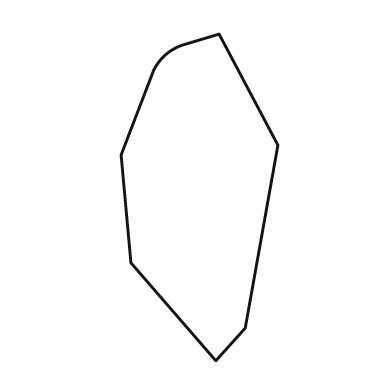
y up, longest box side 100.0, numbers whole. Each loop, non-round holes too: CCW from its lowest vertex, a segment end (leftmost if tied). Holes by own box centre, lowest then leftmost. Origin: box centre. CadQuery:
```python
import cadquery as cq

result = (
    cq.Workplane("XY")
    .moveTo(5.0, -50.0)
    .lineTo(14.0, -40.0)
    .lineTo(24.0, 16.0)
    .lineTo(6.0, 50.0)
    .lineTo(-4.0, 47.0)
    .threePointArc((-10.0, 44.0), (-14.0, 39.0))
    .lineTo(-24.0, 13.0)
    .lineTo(-21.0, -20.0)
    .close()
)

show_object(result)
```